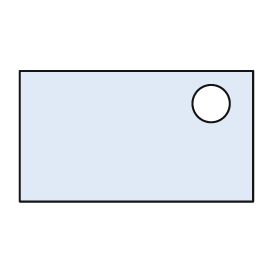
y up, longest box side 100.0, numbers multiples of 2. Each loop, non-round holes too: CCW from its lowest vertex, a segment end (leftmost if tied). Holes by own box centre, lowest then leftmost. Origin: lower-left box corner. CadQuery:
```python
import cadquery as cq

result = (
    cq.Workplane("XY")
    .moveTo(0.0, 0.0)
    .lineTo(100.0, 0.0)
    .lineTo(100.0, 56.0)
    .lineTo(0.0, 56.0)
    .close()
    .moveTo(82.0, 42.0)
    .circle(8.0)
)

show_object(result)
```